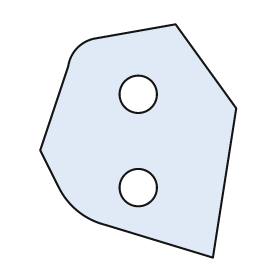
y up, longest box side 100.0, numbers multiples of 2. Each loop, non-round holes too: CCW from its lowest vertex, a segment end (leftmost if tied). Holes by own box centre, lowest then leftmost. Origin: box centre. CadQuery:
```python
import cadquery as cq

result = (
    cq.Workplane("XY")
    .moveTo(32.0, -50.0)
    .lineTo(42.0, 14.0)
    .lineTo(16.0, 50.0)
    .lineTo(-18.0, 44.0)
    .threePointArc((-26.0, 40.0), (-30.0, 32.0))
    .lineTo(-42.0, -4.0)
    .lineTo(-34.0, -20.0)
    .threePointArc((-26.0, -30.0), (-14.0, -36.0))
    .close()
    .moveTo(0.0, -20.0)
    .circle(8.0)
    .moveTo(0.0, 20.0)
    .circle(8.0)
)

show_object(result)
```